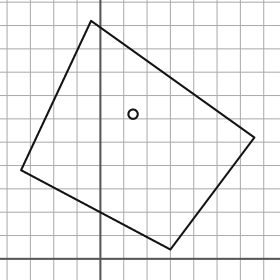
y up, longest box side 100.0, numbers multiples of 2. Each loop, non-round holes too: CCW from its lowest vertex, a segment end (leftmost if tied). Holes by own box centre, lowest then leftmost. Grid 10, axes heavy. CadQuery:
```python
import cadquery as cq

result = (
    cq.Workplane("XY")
    .moveTo(30.0, 4.0)
    .lineTo(66.0, 52.0)
    .lineTo(-4.0, 102.0)
    .lineTo(-34.0, 38.0)
    .close()
    .moveTo(14.0, 62.0)
    .circle(2.0)
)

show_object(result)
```